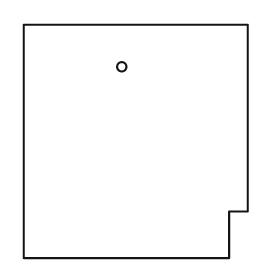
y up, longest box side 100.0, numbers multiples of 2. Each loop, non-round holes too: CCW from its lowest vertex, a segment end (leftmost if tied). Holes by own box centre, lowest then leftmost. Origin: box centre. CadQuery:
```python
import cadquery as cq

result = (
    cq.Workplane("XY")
    .moveTo(-48.0, -50.0)
    .lineTo(40.0, -50.0)
    .lineTo(40.0, -30.0)
    .lineTo(48.0, -30.0)
    .lineTo(48.0, 50.0)
    .lineTo(-48.0, 50.0)
    .close()
    .moveTo(-6.0, 32.0)
    .circle(2.0)
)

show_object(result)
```